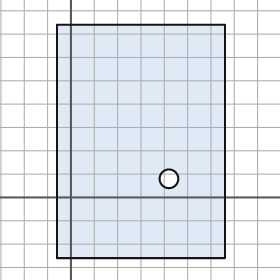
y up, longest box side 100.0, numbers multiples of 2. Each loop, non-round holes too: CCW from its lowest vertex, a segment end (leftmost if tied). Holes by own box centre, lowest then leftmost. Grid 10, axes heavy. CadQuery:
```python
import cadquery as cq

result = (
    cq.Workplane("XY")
    .moveTo(-6.0, -26.0)
    .lineTo(66.0, -26.0)
    .lineTo(66.0, 74.0)
    .lineTo(-6.0, 74.0)
    .close()
    .moveTo(42.0, 8.0)
    .circle(4.0)
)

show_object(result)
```